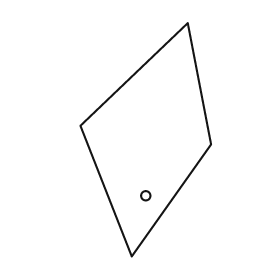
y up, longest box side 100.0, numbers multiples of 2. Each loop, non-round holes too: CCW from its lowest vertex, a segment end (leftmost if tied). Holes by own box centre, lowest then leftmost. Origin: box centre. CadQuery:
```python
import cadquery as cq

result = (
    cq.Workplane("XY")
    .moveTo(-6.0, -50.0)
    .lineTo(28.0, -2.0)
    .lineTo(18.0, 50.0)
    .lineTo(-28.0, 6.0)
    .close()
    .moveTo(0.0, -24.0)
    .circle(2.0)
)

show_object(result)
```